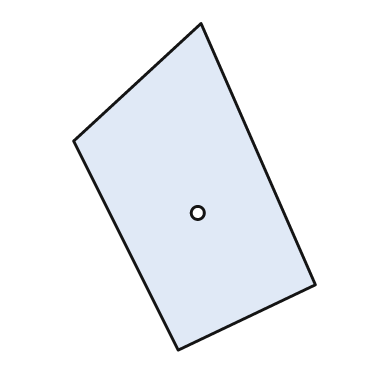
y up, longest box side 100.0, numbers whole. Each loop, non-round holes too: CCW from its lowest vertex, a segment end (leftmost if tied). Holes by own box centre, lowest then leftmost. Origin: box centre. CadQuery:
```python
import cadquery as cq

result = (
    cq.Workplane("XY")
    .moveTo(-5.0, -50.0)
    .lineTo(37.0, -30.0)
    .lineTo(2.0, 50.0)
    .lineTo(-37.0, 14.0)
    .close()
    .moveTo(1.0, -8.0)
    .circle(2.0)
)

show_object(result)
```